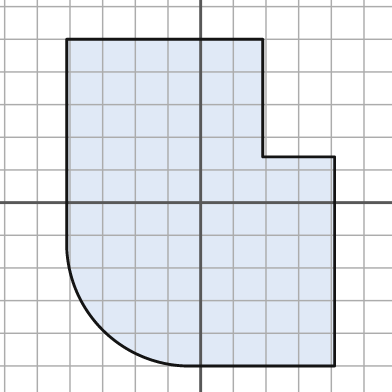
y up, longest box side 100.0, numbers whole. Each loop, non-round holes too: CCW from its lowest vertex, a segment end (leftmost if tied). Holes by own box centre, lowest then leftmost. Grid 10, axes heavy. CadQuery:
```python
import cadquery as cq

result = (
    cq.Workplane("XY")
    .moveTo(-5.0, -50.0)
    .lineTo(41.0, -50.0)
    .lineTo(41.0, 14.0)
    .lineTo(19.0, 14.0)
    .lineTo(19.0, 50.0)
    .lineTo(-41.0, 50.0)
    .lineTo(-41.0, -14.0)
    .threePointArc((-30.0, -39.0), (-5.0, -50.0))
    .close()
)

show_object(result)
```